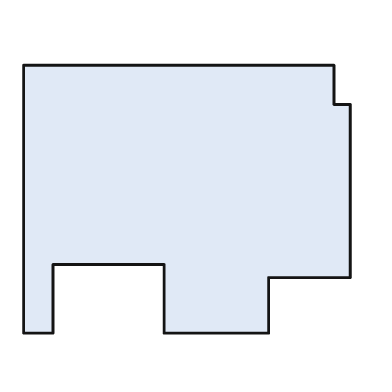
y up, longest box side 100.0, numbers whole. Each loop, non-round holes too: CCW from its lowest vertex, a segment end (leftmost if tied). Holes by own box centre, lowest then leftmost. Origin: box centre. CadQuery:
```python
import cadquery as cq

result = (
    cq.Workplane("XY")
    .moveTo(-50.0, -41.0)
    .lineTo(-41.0, -41.0)
    .lineTo(-41.0, -20.0)
    .lineTo(-7.0, -20.0)
    .lineTo(-7.0, -41.0)
    .lineTo(25.0, -41.0)
    .lineTo(25.0, -24.0)
    .lineTo(50.0, -24.0)
    .lineTo(50.0, 29.0)
    .lineTo(45.0, 29.0)
    .lineTo(45.0, 41.0)
    .lineTo(-50.0, 41.0)
    .close()
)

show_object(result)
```